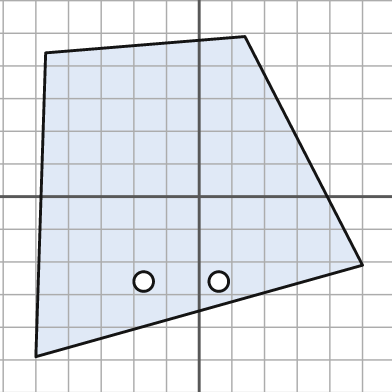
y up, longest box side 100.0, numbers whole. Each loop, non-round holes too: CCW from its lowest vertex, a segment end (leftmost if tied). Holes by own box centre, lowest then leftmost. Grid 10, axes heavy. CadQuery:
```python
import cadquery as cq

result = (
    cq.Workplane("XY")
    .moveTo(-50.0, -49.0)
    .lineTo(50.0, -21.0)
    .lineTo(14.0, 49.0)
    .lineTo(-47.0, 44.0)
    .close()
    .moveTo(-17.0, -26.0)
    .circle(3.0)
    .moveTo(6.0, -26.0)
    .circle(3.0)
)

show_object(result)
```